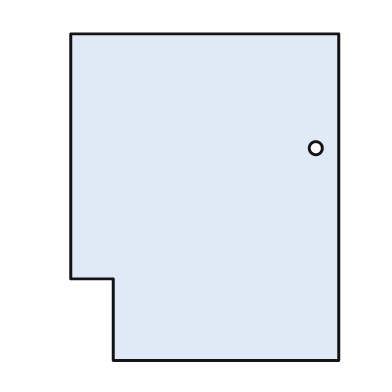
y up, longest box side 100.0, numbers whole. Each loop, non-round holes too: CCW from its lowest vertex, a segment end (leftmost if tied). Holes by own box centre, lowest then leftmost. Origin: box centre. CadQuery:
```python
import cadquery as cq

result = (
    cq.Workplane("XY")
    .moveTo(-28.0, -50.0)
    .lineTo(41.0, -50.0)
    .lineTo(41.0, 50.0)
    .lineTo(-41.0, 50.0)
    .lineTo(-41.0, -25.0)
    .lineTo(-28.0, -25.0)
    .close()
    .moveTo(34.0, 15.0)
    .circle(2.0)
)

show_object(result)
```